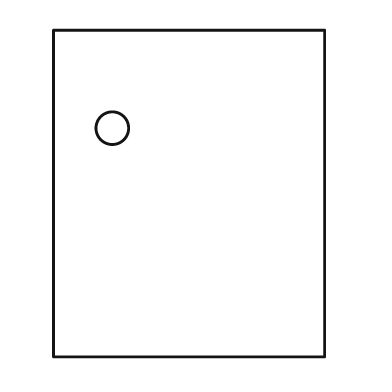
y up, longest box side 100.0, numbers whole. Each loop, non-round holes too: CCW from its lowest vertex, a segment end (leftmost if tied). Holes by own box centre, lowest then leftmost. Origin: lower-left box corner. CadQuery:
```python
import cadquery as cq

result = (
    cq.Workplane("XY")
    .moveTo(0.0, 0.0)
    .lineTo(83.0, 0.0)
    .lineTo(83.0, 100.0)
    .lineTo(0.0, 100.0)
    .close()
    .moveTo(18.0, 70.0)
    .circle(5.0)
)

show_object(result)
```